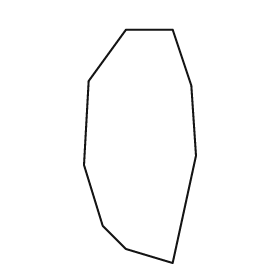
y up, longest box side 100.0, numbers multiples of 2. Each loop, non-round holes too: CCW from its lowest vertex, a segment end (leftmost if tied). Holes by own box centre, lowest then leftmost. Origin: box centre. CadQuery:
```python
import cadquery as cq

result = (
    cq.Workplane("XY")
    .moveTo(14.0, -50.0)
    .lineTo(24.0, -4.0)
    .lineTo(22.0, 26.0)
    .lineTo(14.0, 50.0)
    .lineTo(-6.0, 50.0)
    .lineTo(-22.0, 28.0)
    .lineTo(-24.0, -8.0)
    .lineTo(-16.0, -34.0)
    .lineTo(-6.0, -44.0)
    .close()
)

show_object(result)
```